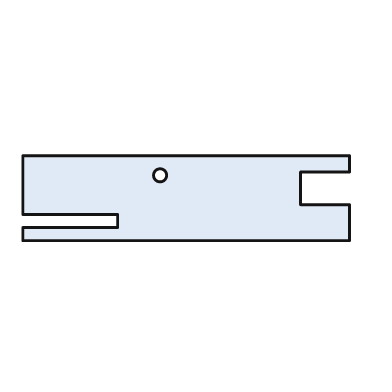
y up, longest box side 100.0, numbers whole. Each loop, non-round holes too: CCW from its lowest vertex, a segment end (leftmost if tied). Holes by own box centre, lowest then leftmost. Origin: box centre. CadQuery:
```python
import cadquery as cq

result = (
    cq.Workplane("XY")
    .moveTo(-50.0, -13.0)
    .lineTo(50.0, -13.0)
    .lineTo(50.0, -2.0)
    .lineTo(35.0, -2.0)
    .lineTo(35.0, 8.0)
    .lineTo(50.0, 8.0)
    .lineTo(50.0, 13.0)
    .lineTo(-50.0, 13.0)
    .lineTo(-50.0, -5.0)
    .lineTo(-21.0, -5.0)
    .lineTo(-21.0, -9.0)
    .lineTo(-50.0, -9.0)
    .close()
    .moveTo(-8.0, 7.0)
    .circle(2.0)
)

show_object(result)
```